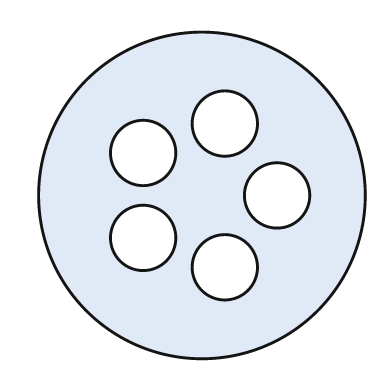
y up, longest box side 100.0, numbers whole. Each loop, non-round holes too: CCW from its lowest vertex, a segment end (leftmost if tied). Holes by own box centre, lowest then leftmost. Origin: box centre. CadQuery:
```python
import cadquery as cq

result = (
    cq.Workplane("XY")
    .moveTo(0.0, 0.0)
    .circle(50.0)
    .moveTo(7.0, -22.0)
    .circle(10.0)
    .moveTo(-18.0, -13.0)
    .circle(10.0)
    .moveTo(23.0, 0.0)
    .circle(10.0)
    .moveTo(-18.0, 13.0)
    .circle(10.0)
    .moveTo(7.0, 22.0)
    .circle(10.0)
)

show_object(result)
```